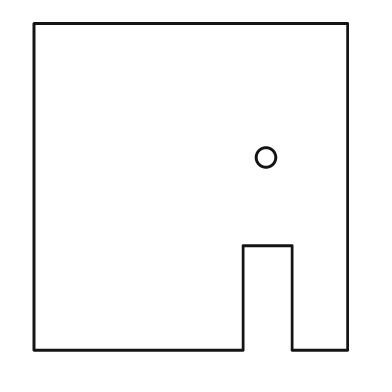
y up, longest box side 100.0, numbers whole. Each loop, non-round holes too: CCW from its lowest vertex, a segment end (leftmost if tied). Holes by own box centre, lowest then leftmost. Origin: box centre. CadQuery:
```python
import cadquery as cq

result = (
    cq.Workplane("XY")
    .moveTo(-48.0, -50.0)
    .lineTo(16.0, -50.0)
    .lineTo(16.0, -18.0)
    .lineTo(31.0, -18.0)
    .lineTo(31.0, -50.0)
    .lineTo(48.0, -50.0)
    .lineTo(48.0, 50.0)
    .lineTo(-48.0, 50.0)
    .close()
    .moveTo(23.0, 9.0)
    .circle(3.0)
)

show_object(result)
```